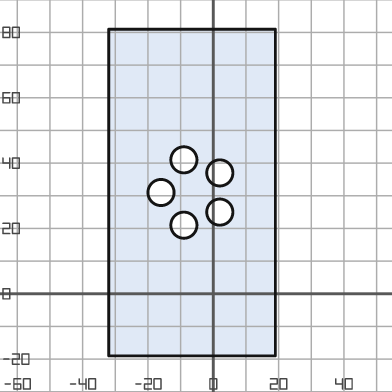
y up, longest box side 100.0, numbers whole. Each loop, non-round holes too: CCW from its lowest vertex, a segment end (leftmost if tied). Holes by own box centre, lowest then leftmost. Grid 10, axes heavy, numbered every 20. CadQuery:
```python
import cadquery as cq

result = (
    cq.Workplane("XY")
    .moveTo(-32.0, -19.0)
    .lineTo(19.0, -19.0)
    .lineTo(19.0, 81.0)
    .lineTo(-32.0, 81.0)
    .close()
    .moveTo(-9.0, 21.0)
    .circle(4.0)
    .moveTo(2.0, 25.0)
    .circle(4.0)
    .moveTo(-16.0, 31.0)
    .circle(4.0)
    .moveTo(2.0, 37.0)
    .circle(4.0)
    .moveTo(-9.0, 41.0)
    .circle(4.0)
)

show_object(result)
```